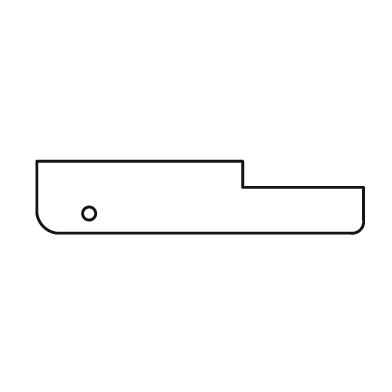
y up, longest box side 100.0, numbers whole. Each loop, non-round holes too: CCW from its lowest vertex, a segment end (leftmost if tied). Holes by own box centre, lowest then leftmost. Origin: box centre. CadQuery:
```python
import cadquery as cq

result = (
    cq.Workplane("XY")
    .moveTo(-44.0, -11.0)
    .lineTo(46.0, -11.0)
    .threePointArc((49.0, -10.0), (50.0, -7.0))
    .lineTo(50.0, 3.0)
    .lineTo(13.0, 3.0)
    .lineTo(13.0, 11.0)
    .lineTo(-50.0, 11.0)
    .lineTo(-50.0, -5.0)
    .threePointArc((-48.0, -9.0), (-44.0, -11.0))
    .close()
    .moveTo(-34.0, -5.0)
    .circle(2.0)
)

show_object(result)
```